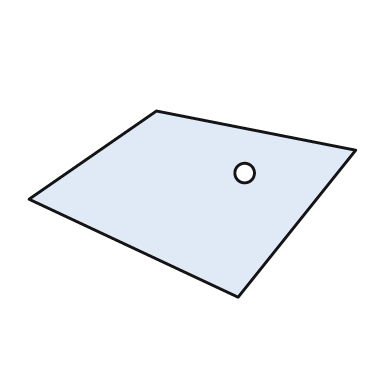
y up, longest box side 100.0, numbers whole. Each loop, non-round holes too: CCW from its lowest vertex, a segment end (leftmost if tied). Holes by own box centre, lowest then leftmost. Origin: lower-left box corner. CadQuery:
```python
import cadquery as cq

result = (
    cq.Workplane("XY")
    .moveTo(64.0, 0.0)
    .lineTo(100.0, 45.0)
    .lineTo(39.0, 57.0)
    .lineTo(0.0, 30.0)
    .close()
    .moveTo(66.0, 38.0)
    .circle(3.0)
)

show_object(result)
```